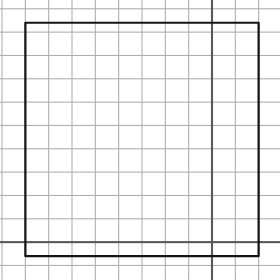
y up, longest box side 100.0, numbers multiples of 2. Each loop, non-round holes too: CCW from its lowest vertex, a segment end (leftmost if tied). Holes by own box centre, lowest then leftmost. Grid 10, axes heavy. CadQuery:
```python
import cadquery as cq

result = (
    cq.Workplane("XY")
    .moveTo(-80.0, -6.0)
    .lineTo(20.0, -6.0)
    .lineTo(20.0, 94.0)
    .lineTo(-80.0, 94.0)
    .close()
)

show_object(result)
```